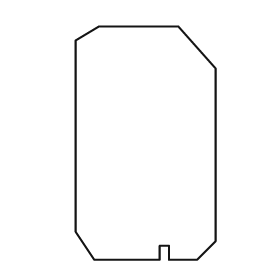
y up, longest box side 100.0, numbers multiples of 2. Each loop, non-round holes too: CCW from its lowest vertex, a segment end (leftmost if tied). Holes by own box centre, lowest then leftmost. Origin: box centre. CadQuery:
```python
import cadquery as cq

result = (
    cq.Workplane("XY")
    .moveTo(-22.0, -50.0)
    .lineTo(6.0, -50.0)
    .lineTo(6.0, -44.0)
    .lineTo(10.0, -44.0)
    .lineTo(10.0, -50.0)
    .lineTo(22.0, -50.0)
    .lineTo(30.0, -42.0)
    .lineTo(30.0, 32.0)
    .lineTo(14.0, 50.0)
    .lineTo(-20.0, 50.0)
    .lineTo(-30.0, 44.0)
    .lineTo(-30.0, -38.0)
    .close()
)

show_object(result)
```